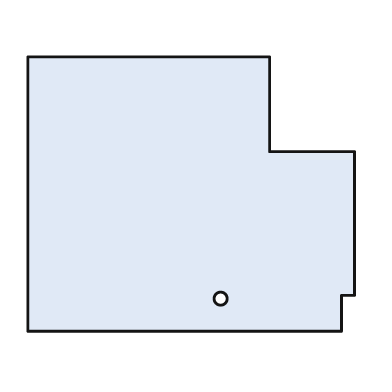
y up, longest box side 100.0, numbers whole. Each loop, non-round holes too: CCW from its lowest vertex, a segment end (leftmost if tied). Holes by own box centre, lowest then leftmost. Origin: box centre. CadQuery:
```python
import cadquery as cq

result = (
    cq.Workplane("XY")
    .moveTo(-50.0, -42.0)
    .lineTo(46.0, -42.0)
    .lineTo(46.0, -31.0)
    .lineTo(50.0, -31.0)
    .lineTo(50.0, 13.0)
    .lineTo(24.0, 13.0)
    .lineTo(24.0, 42.0)
    .lineTo(-50.0, 42.0)
    .close()
    .moveTo(9.0, -32.0)
    .circle(2.0)
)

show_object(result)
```